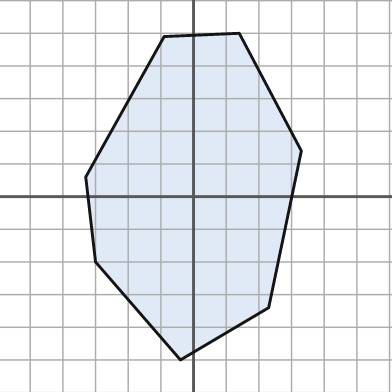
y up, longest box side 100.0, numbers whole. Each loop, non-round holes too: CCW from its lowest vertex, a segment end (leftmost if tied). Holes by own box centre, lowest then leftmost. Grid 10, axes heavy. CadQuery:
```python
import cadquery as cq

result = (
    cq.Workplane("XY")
    .moveTo(-4.0, -50.0)
    .lineTo(23.0, -34.0)
    .lineTo(33.0, 14.0)
    .lineTo(14.0, 50.0)
    .lineTo(-9.0, 49.0)
    .lineTo(-33.0, 6.0)
    .lineTo(-30.0, -20.0)
    .close()
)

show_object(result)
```